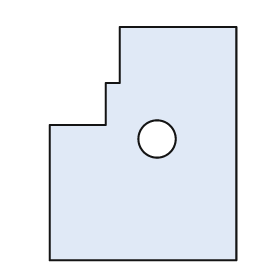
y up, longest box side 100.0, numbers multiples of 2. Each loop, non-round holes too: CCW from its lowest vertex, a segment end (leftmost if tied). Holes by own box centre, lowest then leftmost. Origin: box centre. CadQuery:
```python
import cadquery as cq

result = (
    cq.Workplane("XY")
    .moveTo(-40.0, -50.0)
    .lineTo(40.0, -50.0)
    .lineTo(40.0, 50.0)
    .lineTo(-10.0, 50.0)
    .lineTo(-10.0, 26.0)
    .lineTo(-16.0, 26.0)
    .lineTo(-16.0, 8.0)
    .lineTo(-40.0, 8.0)
    .close()
    .moveTo(6.0, 2.0)
    .circle(8.0)
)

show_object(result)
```